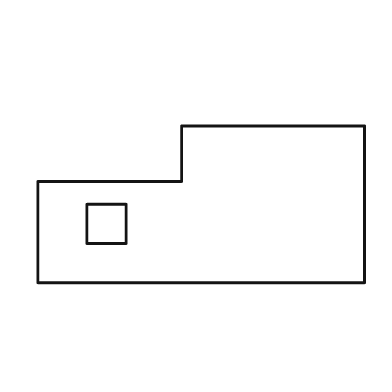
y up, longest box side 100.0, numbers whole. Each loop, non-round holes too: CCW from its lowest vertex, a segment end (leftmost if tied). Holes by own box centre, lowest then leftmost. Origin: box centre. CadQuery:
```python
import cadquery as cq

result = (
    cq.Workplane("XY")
    .moveTo(-50.0, -24.0)
    .lineTo(50.0, -24.0)
    .lineTo(50.0, 24.0)
    .lineTo(-6.0, 24.0)
    .lineTo(-6.0, 7.0)
    .lineTo(-50.0, 7.0)
    .close()
    .moveTo(-35.0, -12.0)
    .lineTo(-23.0, -12.0)
    .lineTo(-23.0, 0.0)
    .lineTo(-35.0, 0.0)
    .close()
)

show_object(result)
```